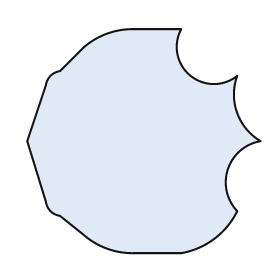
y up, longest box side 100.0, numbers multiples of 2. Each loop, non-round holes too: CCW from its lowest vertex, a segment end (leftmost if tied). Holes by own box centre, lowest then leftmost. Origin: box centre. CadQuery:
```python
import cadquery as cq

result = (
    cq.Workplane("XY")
    .moveTo(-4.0, -48.0)
    .lineTo(16.0, -48.0)
    .threePointArc((30.0, -42.0), (40.0, -30.0))
    .threePointArc((36.0, -12.0), (50.0, 0.0))
    .threePointArc((40.0, 12.0), (40.0, 28.0))
    .threePointArc((20.0, 28.0), (16.0, 48.0))
    .lineTo(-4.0, 48.0)
    .threePointArc((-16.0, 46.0), (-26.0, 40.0))
    .lineTo(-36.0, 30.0)
    .threePointArc((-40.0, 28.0), (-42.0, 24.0))
    .lineTo(-50.0, 0.0)
    .lineTo(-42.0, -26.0)
    .threePointArc((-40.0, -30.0), (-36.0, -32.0))
    .lineTo(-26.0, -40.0)
    .threePointArc((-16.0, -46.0), (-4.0, -48.0))
    .close()
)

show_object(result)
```